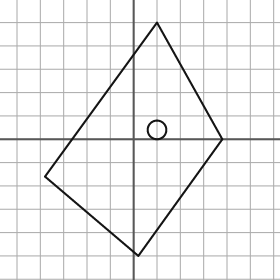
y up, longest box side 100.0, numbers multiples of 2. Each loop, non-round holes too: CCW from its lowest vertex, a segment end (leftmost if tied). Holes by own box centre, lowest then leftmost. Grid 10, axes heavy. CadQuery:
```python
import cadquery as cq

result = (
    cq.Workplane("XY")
    .moveTo(2.0, -50.0)
    .lineTo(38.0, 0.0)
    .lineTo(10.0, 50.0)
    .lineTo(-38.0, -16.0)
    .close()
    .moveTo(10.0, 4.0)
    .circle(4.0)
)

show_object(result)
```